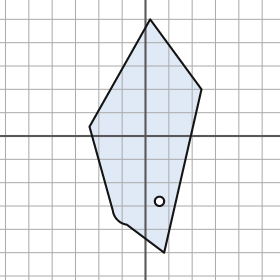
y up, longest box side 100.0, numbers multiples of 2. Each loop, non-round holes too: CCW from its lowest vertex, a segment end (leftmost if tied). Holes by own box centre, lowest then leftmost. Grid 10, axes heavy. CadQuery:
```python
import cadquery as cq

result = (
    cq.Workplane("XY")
    .moveTo(8.0, -50.0)
    .lineTo(24.0, 20.0)
    .lineTo(2.0, 50.0)
    .lineTo(-24.0, 4.0)
    .lineTo(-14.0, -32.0)
    .threePointArc((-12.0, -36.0), (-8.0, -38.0))
    .close()
    .moveTo(6.0, -28.0)
    .circle(2.0)
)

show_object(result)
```